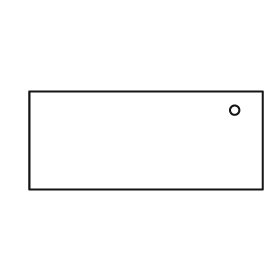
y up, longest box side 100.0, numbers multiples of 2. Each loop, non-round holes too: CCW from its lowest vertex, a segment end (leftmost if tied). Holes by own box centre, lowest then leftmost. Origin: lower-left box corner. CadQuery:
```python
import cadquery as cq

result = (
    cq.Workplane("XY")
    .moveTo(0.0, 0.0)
    .lineTo(100.0, 0.0)
    .lineTo(100.0, 42.0)
    .lineTo(0.0, 42.0)
    .close()
    .moveTo(88.0, 34.0)
    .circle(2.0)
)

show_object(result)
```